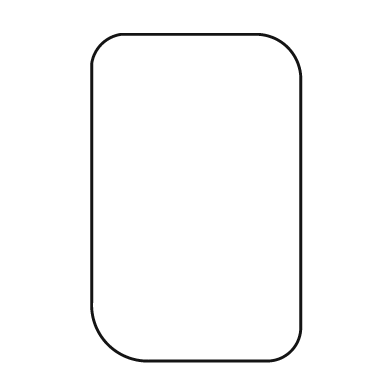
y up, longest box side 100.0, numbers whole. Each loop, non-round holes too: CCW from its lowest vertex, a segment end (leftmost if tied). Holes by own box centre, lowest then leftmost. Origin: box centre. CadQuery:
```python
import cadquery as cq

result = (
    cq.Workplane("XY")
    .moveTo(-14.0, -50.0)
    .lineTo(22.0, -50.0)
    .threePointArc((29.0, -47.0), (32.0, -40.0))
    .lineTo(32.0, 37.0)
    .threePointArc((28.0, 46.0), (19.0, 50.0))
    .lineTo(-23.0, 50.0)
    .threePointArc((-29.0, 47.0), (-32.0, 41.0))
    .lineTo(-32.0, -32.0)
    .threePointArc((-27.0, -45.0), (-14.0, -50.0))
    .close()
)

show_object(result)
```